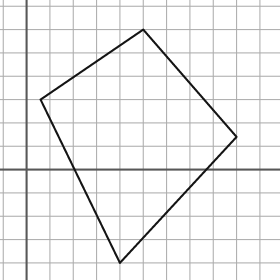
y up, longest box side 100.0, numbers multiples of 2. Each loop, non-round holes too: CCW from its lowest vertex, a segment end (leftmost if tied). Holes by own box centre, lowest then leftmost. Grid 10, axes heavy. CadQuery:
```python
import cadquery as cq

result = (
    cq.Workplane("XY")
    .moveTo(40.0, -40.0)
    .lineTo(90.0, 14.0)
    .lineTo(50.0, 60.0)
    .lineTo(6.0, 30.0)
    .close()
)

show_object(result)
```